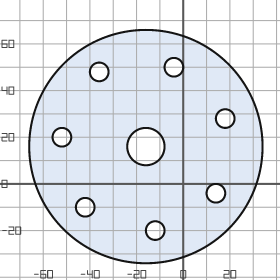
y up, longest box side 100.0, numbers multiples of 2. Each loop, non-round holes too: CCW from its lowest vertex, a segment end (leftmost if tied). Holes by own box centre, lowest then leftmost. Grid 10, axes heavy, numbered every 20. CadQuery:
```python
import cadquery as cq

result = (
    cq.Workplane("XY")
    .moveTo(-16.0, 16.0)
    .circle(50.0)
    .moveTo(-12.0, -20.0)
    .circle(4.0)
    .moveTo(-42.0, -10.0)
    .circle(4.0)
    .moveTo(14.0, -4.0)
    .circle(4.0)
    .moveTo(-16.0, 16.0)
    .circle(8.0)
    .moveTo(-52.0, 20.0)
    .circle(4.0)
    .moveTo(18.0, 28.0)
    .circle(4.0)
    .moveTo(-36.0, 48.0)
    .circle(4.0)
    .moveTo(-4.0, 50.0)
    .circle(4.0)
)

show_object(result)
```